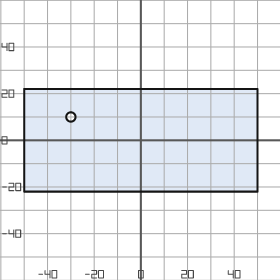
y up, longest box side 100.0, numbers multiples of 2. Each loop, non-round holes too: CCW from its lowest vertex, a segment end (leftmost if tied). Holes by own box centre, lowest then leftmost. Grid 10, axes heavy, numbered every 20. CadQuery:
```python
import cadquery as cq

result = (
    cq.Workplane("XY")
    .moveTo(-50.0, -22.0)
    .lineTo(50.0, -22.0)
    .lineTo(50.0, 22.0)
    .lineTo(-50.0, 22.0)
    .close()
    .moveTo(-30.0, 10.0)
    .circle(2.0)
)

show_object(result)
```